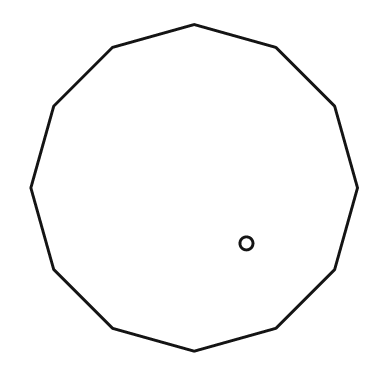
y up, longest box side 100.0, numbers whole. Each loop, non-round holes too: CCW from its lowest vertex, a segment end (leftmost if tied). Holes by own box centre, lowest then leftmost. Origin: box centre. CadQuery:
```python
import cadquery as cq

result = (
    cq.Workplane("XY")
    .moveTo(0.0, -50.0)
    .lineTo(25.0, -43.0)
    .lineTo(43.0, -25.0)
    .lineTo(50.0, 0.0)
    .lineTo(43.0, 25.0)
    .lineTo(25.0, 43.0)
    .lineTo(0.0, 50.0)
    .lineTo(-25.0, 43.0)
    .lineTo(-43.0, 25.0)
    .lineTo(-50.0, 0.0)
    .lineTo(-43.0, -25.0)
    .lineTo(-25.0, -43.0)
    .close()
    .moveTo(16.0, -17.0)
    .circle(2.0)
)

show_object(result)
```